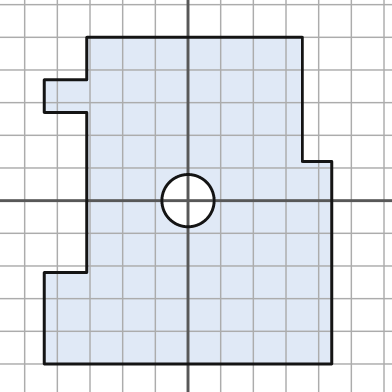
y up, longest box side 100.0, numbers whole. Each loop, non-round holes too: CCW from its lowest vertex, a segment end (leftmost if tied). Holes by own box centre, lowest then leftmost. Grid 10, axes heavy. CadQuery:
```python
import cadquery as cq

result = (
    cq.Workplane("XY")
    .moveTo(-44.0, -50.0)
    .lineTo(44.0, -50.0)
    .lineTo(44.0, 12.0)
    .lineTo(35.0, 12.0)
    .lineTo(35.0, 50.0)
    .lineTo(-31.0, 50.0)
    .lineTo(-31.0, 37.0)
    .lineTo(-44.0, 37.0)
    .lineTo(-44.0, 27.0)
    .lineTo(-31.0, 27.0)
    .lineTo(-31.0, -22.0)
    .lineTo(-44.0, -22.0)
    .close()
    .moveTo(0.0, 0.0)
    .circle(8.0)
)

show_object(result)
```